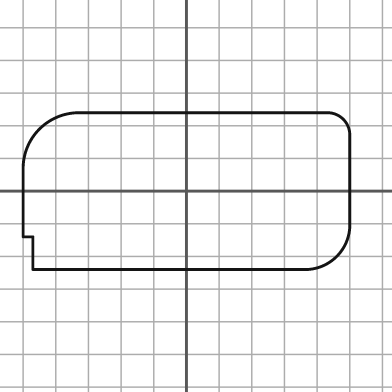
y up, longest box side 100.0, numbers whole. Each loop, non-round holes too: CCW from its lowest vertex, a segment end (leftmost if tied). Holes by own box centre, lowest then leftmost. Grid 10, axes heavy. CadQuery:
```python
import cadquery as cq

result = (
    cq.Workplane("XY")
    .moveTo(-47.0, -24.0)
    .lineTo(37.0, -24.0)
    .threePointArc((46.0, -20.0), (50.0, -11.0))
    .lineTo(50.0, 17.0)
    .threePointArc((48.0, 22.0), (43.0, 24.0))
    .lineTo(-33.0, 24.0)
    .threePointArc((-45.0, 19.0), (-50.0, 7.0))
    .lineTo(-50.0, -14.0)
    .lineTo(-47.0, -14.0)
    .close()
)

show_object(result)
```